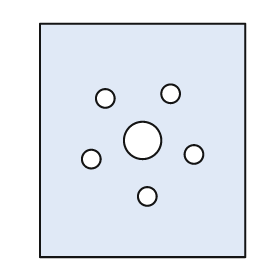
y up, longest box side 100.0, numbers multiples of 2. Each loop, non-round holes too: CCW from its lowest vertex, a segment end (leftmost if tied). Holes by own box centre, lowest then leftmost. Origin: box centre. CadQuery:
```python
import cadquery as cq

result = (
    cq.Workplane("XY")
    .moveTo(-44.0, -50.0)
    .lineTo(44.0, -50.0)
    .lineTo(44.0, 50.0)
    .lineTo(-44.0, 50.0)
    .close()
    .moveTo(2.0, -24.0)
    .circle(4.0)
    .moveTo(-22.0, -8.0)
    .circle(4.0)
    .moveTo(22.0, -6.0)
    .circle(4.0)
    .moveTo(0.0, 0.0)
    .circle(8.0)
    .moveTo(-16.0, 18.0)
    .circle(4.0)
    .moveTo(12.0, 20.0)
    .circle(4.0)
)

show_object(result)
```